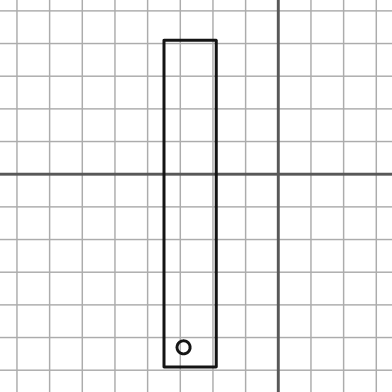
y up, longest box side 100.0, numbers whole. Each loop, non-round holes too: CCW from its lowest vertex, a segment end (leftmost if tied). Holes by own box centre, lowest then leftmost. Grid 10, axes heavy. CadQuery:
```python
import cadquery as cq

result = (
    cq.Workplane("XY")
    .moveTo(-35.0, -59.0)
    .lineTo(-19.0, -59.0)
    .lineTo(-19.0, 41.0)
    .lineTo(-35.0, 41.0)
    .close()
    .moveTo(-29.0, -53.0)
    .circle(2.0)
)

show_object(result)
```